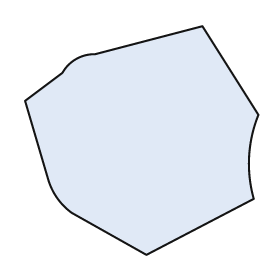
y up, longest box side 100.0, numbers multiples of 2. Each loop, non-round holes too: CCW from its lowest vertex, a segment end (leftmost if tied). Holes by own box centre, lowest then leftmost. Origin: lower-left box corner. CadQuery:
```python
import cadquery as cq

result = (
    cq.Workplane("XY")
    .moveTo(52.0, 0.0)
    .lineTo(98.0, 24.0)
    .threePointArc((96.0, 42.0), (100.0, 60.0))
    .lineTo(76.0, 98.0)
    .lineTo(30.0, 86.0)
    .threePointArc((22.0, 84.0), (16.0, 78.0))
    .lineTo(0.0, 66.0)
    .lineTo(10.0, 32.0)
    .threePointArc((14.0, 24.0), (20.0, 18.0))
    .close()
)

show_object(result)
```